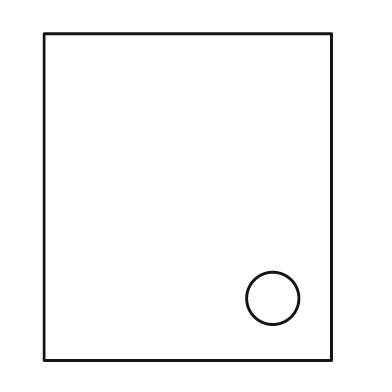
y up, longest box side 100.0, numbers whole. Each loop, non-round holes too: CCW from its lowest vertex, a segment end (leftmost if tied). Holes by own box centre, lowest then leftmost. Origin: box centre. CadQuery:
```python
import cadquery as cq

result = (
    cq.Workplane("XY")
    .moveTo(-44.0, -50.0)
    .lineTo(44.0, -50.0)
    .lineTo(44.0, 50.0)
    .lineTo(-44.0, 50.0)
    .close()
    .moveTo(26.0, -31.0)
    .circle(8.0)
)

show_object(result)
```